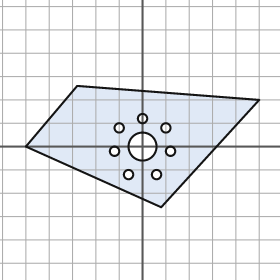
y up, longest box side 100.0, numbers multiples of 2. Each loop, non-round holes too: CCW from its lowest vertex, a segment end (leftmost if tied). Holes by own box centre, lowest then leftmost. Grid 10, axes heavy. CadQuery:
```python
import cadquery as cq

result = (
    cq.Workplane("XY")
    .moveTo(8.0, -26.0)
    .lineTo(50.0, 20.0)
    .lineTo(-28.0, 26.0)
    .lineTo(-50.0, 0.0)
    .close()
    .moveTo(-6.0, -12.0)
    .circle(2.0)
    .moveTo(6.0, -12.0)
    .circle(2.0)
    .moveTo(-12.0, -2.0)
    .circle(2.0)
    .moveTo(12.0, -2.0)
    .circle(2.0)
    .moveTo(0.0, 0.0)
    .circle(6.0)
    .moveTo(-10.0, 8.0)
    .circle(2.0)
    .moveTo(10.0, 8.0)
    .circle(2.0)
    .moveTo(0.0, 12.0)
    .circle(2.0)
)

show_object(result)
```